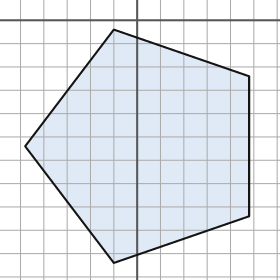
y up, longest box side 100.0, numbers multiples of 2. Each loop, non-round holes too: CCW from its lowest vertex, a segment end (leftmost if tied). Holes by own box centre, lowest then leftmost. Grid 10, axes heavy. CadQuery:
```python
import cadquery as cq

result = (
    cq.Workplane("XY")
    .moveTo(-10.0, -104.0)
    .lineTo(48.0, -84.0)
    .lineTo(48.0, -24.0)
    .lineTo(-10.0, -4.0)
    .lineTo(-48.0, -54.0)
    .close()
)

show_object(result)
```